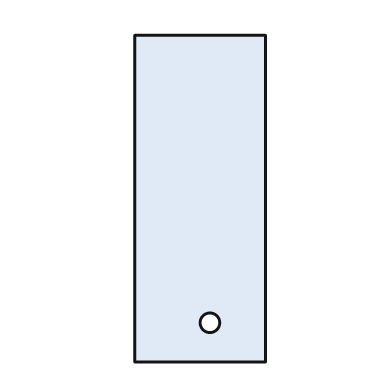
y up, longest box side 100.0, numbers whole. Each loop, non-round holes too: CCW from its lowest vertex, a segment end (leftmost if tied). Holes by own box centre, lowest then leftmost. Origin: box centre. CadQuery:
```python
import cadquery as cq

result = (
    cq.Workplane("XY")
    .moveTo(-20.0, -50.0)
    .lineTo(20.0, -50.0)
    .lineTo(20.0, 50.0)
    .lineTo(-20.0, 50.0)
    .close()
    .moveTo(3.0, -38.0)
    .circle(3.0)
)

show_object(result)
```